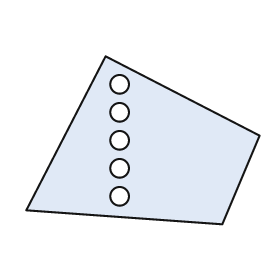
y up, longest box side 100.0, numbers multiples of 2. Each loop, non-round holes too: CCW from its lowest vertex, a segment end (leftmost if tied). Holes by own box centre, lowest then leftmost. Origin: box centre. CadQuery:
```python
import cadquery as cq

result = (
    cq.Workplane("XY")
    .moveTo(34.0, -36.0)
    .lineTo(50.0, 2.0)
    .lineTo(-16.0, 36.0)
    .lineTo(-50.0, -30.0)
    .close()
    .moveTo(-10.0, -24.0)
    .circle(4.0)
    .moveTo(-10.0, -12.0)
    .circle(4.0)
    .moveTo(-10.0, 0.0)
    .circle(4.0)
    .moveTo(-10.0, 12.0)
    .circle(4.0)
    .moveTo(-10.0, 24.0)
    .circle(4.0)
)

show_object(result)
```